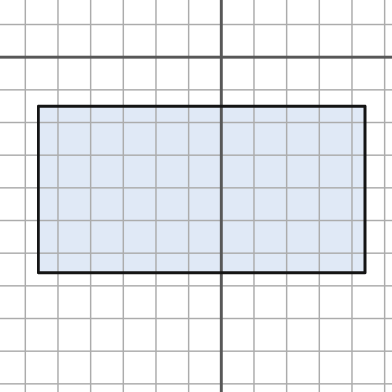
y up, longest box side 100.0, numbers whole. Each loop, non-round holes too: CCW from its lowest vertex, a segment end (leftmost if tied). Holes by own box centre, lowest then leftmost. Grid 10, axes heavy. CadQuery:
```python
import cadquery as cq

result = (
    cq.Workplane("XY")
    .moveTo(-56.0, -66.0)
    .lineTo(44.0, -66.0)
    .lineTo(44.0, -15.0)
    .lineTo(-56.0, -15.0)
    .close()
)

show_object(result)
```